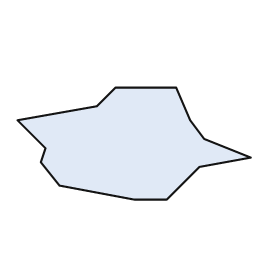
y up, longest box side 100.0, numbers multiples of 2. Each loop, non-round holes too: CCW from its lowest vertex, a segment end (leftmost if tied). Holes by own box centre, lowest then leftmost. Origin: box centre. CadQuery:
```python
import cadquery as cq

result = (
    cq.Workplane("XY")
    .moveTo(0.0, -24.0)
    .lineTo(14.0, -24.0)
    .lineTo(28.0, -10.0)
    .lineTo(50.0, -6.0)
    .lineTo(30.0, 2.0)
    .lineTo(24.0, 10.0)
    .lineTo(18.0, 24.0)
    .lineTo(-8.0, 24.0)
    .lineTo(-16.0, 16.0)
    .lineTo(-50.0, 10.0)
    .lineTo(-38.0, -2.0)
    .lineTo(-40.0, -8.0)
    .lineTo(-32.0, -18.0)
    .close()
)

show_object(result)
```